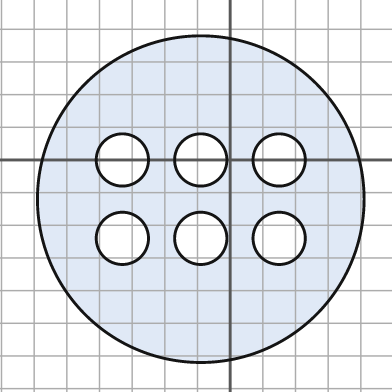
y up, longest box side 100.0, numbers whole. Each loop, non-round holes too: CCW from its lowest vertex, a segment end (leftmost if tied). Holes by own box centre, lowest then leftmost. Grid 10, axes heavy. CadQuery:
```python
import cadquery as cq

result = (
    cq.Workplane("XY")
    .moveTo(-9.0, -12.0)
    .circle(50.0)
    .moveTo(-33.0, -24.0)
    .circle(8.0)
    .moveTo(-9.0, -24.0)
    .circle(8.0)
    .moveTo(15.0, -24.0)
    .circle(8.0)
    .moveTo(-33.0, 0.0)
    .circle(8.0)
    .moveTo(-9.0, 0.0)
    .circle(8.0)
    .moveTo(15.0, 0.0)
    .circle(8.0)
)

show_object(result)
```